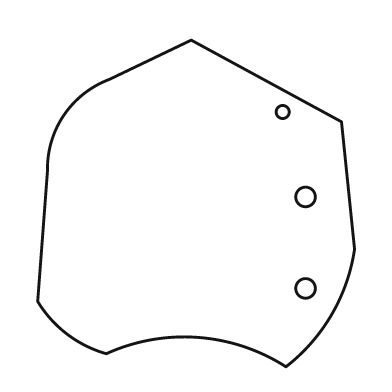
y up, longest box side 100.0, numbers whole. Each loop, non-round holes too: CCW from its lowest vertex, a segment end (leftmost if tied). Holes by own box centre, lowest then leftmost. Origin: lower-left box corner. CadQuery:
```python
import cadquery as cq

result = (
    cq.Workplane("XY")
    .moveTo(76.0, 0.0)
    .threePointArc((90.0, 16.0), (97.0, 36.0))
    .lineTo(93.0, 75.0)
    .lineTo(47.0, 100.0)
    .lineTo(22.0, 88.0)
    .threePointArc((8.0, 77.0), (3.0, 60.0))
    .lineTo(0.0, 20.0)
    .threePointArc((9.0, 10.0), (21.0, 4.0))
    .threePointArc((49.0, 9.0), (76.0, 0.0))
    .close()
    .moveTo(82.0, 24.0)
    .circle(3.0)
    .moveTo(82.0, 52.0)
    .circle(3.0)
    .moveTo(75.0, 78.0)
    .circle(2.0)
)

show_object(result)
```